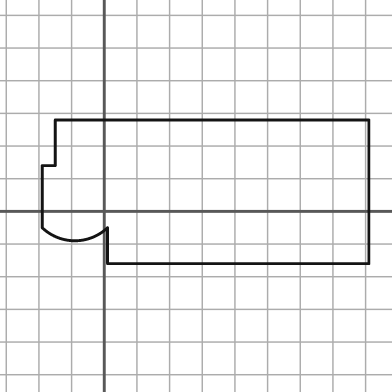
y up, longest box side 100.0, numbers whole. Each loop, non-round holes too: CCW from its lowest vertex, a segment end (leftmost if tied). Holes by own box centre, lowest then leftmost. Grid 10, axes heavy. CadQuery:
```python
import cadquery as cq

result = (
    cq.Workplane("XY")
    .moveTo(1.0, -16.0)
    .lineTo(81.0, -16.0)
    .lineTo(81.0, 28.0)
    .lineTo(-15.0, 28.0)
    .lineTo(-15.0, 14.0)
    .lineTo(-19.0, 14.0)
    .lineTo(-19.0, -5.0)
    .threePointArc((-9.0, -9.0), (1.0, -5.0))
    .close()
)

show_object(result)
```